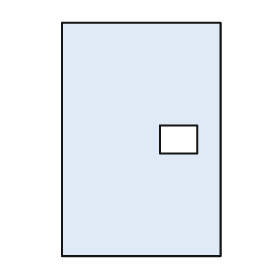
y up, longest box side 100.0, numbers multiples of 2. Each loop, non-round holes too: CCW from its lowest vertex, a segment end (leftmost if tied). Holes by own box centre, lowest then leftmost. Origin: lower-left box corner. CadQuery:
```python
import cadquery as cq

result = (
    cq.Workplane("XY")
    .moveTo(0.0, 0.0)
    .lineTo(68.0, 0.0)
    .lineTo(68.0, 100.0)
    .lineTo(0.0, 100.0)
    .close()
    .moveTo(42.0, 44.0)
    .lineTo(58.0, 44.0)
    .lineTo(58.0, 56.0)
    .lineTo(42.0, 56.0)
    .close()
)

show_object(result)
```